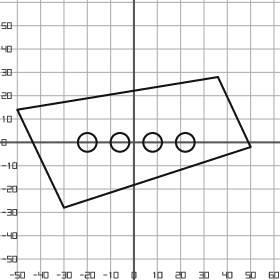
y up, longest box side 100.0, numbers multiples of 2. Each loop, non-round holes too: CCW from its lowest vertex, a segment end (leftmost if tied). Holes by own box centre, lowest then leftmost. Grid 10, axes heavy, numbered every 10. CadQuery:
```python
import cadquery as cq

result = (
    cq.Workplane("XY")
    .moveTo(-30.0, -28.0)
    .lineTo(50.0, -2.0)
    .lineTo(36.0, 28.0)
    .lineTo(-50.0, 14.0)
    .close()
    .moveTo(-20.0, 0.0)
    .circle(4.0)
    .moveTo(-6.0, 0.0)
    .circle(4.0)
    .moveTo(8.0, 0.0)
    .circle(4.0)
    .moveTo(22.0, 0.0)
    .circle(4.0)
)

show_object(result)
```